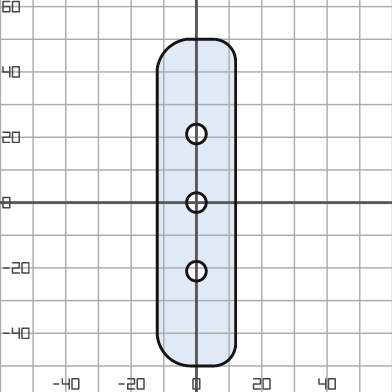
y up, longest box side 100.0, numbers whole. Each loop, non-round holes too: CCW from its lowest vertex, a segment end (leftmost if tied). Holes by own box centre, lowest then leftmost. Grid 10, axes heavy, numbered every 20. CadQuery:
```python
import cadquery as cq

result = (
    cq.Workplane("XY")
    .moveTo(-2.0, -50.0)
    .lineTo(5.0, -50.0)
    .threePointArc((10.0, -48.0), (12.0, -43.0))
    .lineTo(12.0, 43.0)
    .threePointArc((10.0, 48.0), (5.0, 50.0))
    .lineTo(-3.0, 50.0)
    .threePointArc((-9.0, 47.0), (-12.0, 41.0))
    .lineTo(-12.0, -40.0)
    .threePointArc((-9.0, -47.0), (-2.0, -50.0))
    .close()
    .moveTo(0.0, -21.0)
    .circle(3.0)
    .moveTo(0.0, 0.0)
    .circle(3.0)
    .moveTo(0.0, 21.0)
    .circle(3.0)
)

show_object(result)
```